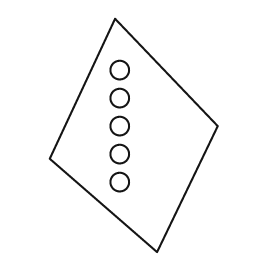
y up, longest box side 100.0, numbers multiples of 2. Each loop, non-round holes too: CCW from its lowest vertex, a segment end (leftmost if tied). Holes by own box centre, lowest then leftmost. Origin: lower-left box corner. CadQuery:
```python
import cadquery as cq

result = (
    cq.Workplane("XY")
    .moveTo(46.0, 0.0)
    .lineTo(72.0, 54.0)
    .lineTo(28.0, 100.0)
    .lineTo(0.0, 40.0)
    .close()
    .moveTo(30.0, 30.0)
    .circle(4.0)
    .moveTo(30.0, 42.0)
    .circle(4.0)
    .moveTo(30.0, 54.0)
    .circle(4.0)
    .moveTo(30.0, 66.0)
    .circle(4.0)
    .moveTo(30.0, 78.0)
    .circle(4.0)
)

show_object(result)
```